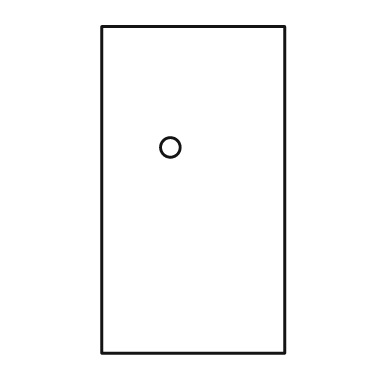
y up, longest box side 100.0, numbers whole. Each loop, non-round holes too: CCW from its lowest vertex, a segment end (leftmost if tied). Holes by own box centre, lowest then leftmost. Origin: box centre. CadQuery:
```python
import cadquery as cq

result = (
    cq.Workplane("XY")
    .moveTo(-28.0, -50.0)
    .lineTo(28.0, -50.0)
    .lineTo(28.0, 50.0)
    .lineTo(-28.0, 50.0)
    .close()
    .moveTo(-7.0, 13.0)
    .circle(3.0)
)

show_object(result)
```